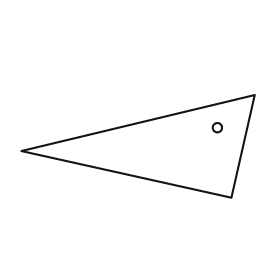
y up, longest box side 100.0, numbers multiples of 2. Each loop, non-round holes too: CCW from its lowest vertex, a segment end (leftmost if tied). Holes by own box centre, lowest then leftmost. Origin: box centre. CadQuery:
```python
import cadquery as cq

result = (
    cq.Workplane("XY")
    .moveTo(40.0, -22.0)
    .lineTo(50.0, 22.0)
    .lineTo(-50.0, -2.0)
    .close()
    .moveTo(34.0, 8.0)
    .circle(2.0)
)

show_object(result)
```